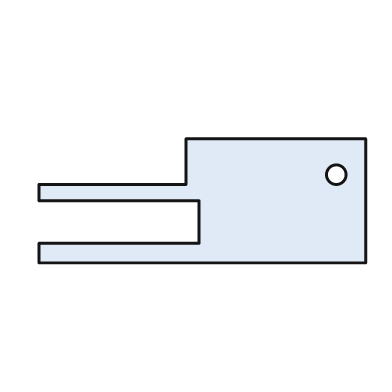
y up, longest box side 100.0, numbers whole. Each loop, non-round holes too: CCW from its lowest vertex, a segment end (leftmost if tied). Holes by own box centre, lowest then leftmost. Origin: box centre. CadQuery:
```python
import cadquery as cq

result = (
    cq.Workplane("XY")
    .moveTo(-50.0, -19.0)
    .lineTo(50.0, -19.0)
    .lineTo(50.0, 19.0)
    .lineTo(-5.0, 19.0)
    .lineTo(-5.0, 5.0)
    .lineTo(-50.0, 5.0)
    .lineTo(-50.0, 0.0)
    .lineTo(-1.0, 0.0)
    .lineTo(-1.0, -13.0)
    .lineTo(-50.0, -13.0)
    .close()
    .moveTo(41.0, 8.0)
    .circle(3.0)
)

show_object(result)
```